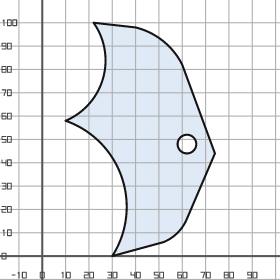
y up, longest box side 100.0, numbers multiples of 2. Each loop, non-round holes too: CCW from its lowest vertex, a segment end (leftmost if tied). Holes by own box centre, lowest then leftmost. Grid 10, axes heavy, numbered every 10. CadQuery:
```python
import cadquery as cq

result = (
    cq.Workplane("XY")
    .moveTo(30.0, 0.0)
    .lineTo(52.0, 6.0)
    .threePointArc((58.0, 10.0), (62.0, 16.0))
    .lineTo(74.0, 44.0)
    .lineTo(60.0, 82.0)
    .threePointArc((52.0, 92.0), (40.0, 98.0))
    .lineTo(22.0, 100.0)
    .threePointArc((26.0, 76.0), (10.0, 58.0))
    .threePointArc((34.0, 34.0), (30.0, 0.0))
    .close()
    .moveTo(62.0, 48.0)
    .circle(4.0)
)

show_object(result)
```